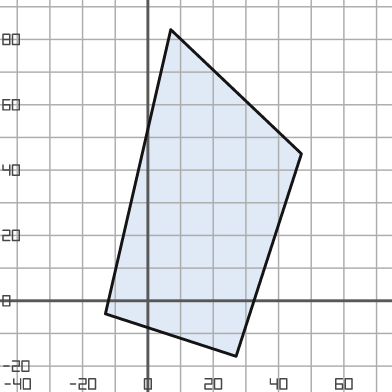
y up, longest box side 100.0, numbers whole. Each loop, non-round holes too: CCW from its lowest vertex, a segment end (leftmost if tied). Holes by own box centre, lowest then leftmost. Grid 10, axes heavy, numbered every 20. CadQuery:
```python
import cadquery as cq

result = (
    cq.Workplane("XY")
    .moveTo(27.0, -17.0)
    .lineTo(47.0, 45.0)
    .lineTo(7.0, 83.0)
    .lineTo(-13.0, -4.0)
    .close()
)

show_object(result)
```